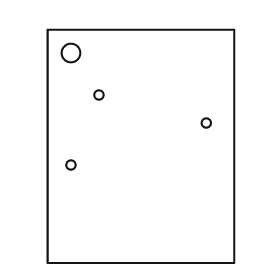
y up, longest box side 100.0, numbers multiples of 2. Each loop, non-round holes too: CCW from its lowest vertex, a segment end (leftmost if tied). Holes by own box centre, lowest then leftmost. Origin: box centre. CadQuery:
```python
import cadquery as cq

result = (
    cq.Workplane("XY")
    .moveTo(-40.0, -50.0)
    .lineTo(40.0, -50.0)
    .lineTo(40.0, 50.0)
    .lineTo(-40.0, 50.0)
    .close()
    .moveTo(-30.0, -8.0)
    .circle(2.0)
    .moveTo(28.0, 10.0)
    .circle(2.0)
    .moveTo(-18.0, 22.0)
    .circle(2.0)
    .moveTo(-30.0, 40.0)
    .circle(4.0)
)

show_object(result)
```